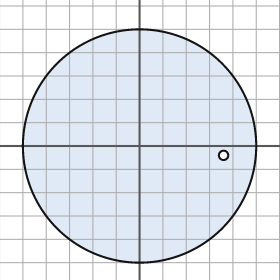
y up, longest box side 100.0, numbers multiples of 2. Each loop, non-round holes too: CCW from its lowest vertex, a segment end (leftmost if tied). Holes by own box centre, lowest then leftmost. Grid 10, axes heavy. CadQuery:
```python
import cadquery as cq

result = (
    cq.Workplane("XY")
    .moveTo(0.0, 0.0)
    .circle(50.0)
    .moveTo(36.0, -4.0)
    .circle(2.0)
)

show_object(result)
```